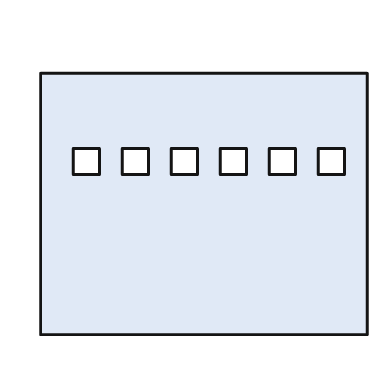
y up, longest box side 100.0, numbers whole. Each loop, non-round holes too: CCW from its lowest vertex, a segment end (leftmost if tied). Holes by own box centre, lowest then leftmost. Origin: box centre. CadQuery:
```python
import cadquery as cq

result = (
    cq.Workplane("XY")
    .moveTo(-50.0, -40.0)
    .lineTo(50.0, -40.0)
    .lineTo(50.0, 40.0)
    .lineTo(-50.0, 40.0)
    .close()
    .moveTo(-40.0, 9.0)
    .lineTo(-32.0, 9.0)
    .lineTo(-32.0, 17.0)
    .lineTo(-40.0, 17.0)
    .close()
    .moveTo(-25.0, 9.0)
    .lineTo(-17.0, 9.0)
    .lineTo(-17.0, 17.0)
    .lineTo(-25.0, 17.0)
    .close()
    .moveTo(-10.0, 9.0)
    .lineTo(-2.0, 9.0)
    .lineTo(-2.0, 17.0)
    .lineTo(-10.0, 17.0)
    .close()
    .moveTo(5.0, 9.0)
    .lineTo(13.0, 9.0)
    .lineTo(13.0, 17.0)
    .lineTo(5.0, 17.0)
    .close()
    .moveTo(20.0, 9.0)
    .lineTo(28.0, 9.0)
    .lineTo(28.0, 17.0)
    .lineTo(20.0, 17.0)
    .close()
    .moveTo(35.0, 9.0)
    .lineTo(43.0, 9.0)
    .lineTo(43.0, 17.0)
    .lineTo(35.0, 17.0)
    .close()
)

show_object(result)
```